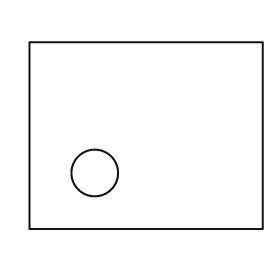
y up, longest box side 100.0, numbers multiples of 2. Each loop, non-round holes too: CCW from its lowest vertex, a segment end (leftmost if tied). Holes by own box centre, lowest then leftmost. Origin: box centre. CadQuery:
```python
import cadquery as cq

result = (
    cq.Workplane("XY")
    .moveTo(-50.0, -40.0)
    .lineTo(50.0, -40.0)
    .lineTo(50.0, 40.0)
    .lineTo(-50.0, 40.0)
    .close()
    .moveTo(-22.0, -16.0)
    .circle(10.0)
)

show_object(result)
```